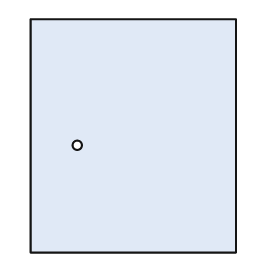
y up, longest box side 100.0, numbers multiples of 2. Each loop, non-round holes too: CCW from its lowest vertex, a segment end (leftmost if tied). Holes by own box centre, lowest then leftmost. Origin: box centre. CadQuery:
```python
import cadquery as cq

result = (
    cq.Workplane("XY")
    .moveTo(-44.0, -50.0)
    .lineTo(44.0, -50.0)
    .lineTo(44.0, 50.0)
    .lineTo(-44.0, 50.0)
    .close()
    .moveTo(-24.0, -4.0)
    .circle(2.0)
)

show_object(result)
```